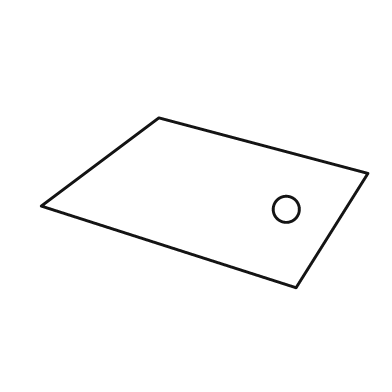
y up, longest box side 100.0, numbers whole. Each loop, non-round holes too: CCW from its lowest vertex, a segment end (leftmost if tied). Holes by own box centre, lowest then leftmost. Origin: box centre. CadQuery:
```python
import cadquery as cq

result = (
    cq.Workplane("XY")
    .moveTo(28.0, -26.0)
    .lineTo(50.0, 9.0)
    .lineTo(-14.0, 26.0)
    .lineTo(-50.0, -1.0)
    .close()
    .moveTo(25.0, -2.0)
    .circle(4.0)
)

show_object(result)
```